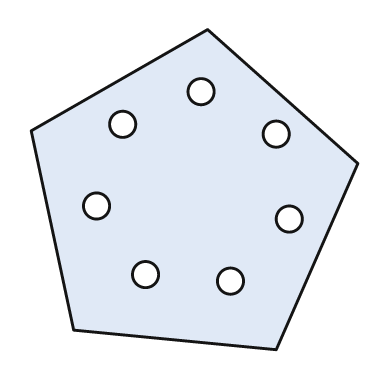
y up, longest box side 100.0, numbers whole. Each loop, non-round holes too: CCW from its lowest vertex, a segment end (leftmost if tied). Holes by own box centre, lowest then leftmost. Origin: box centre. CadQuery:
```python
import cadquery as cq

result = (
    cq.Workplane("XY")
    .moveTo(25.0, -49.0)
    .lineTo(50.0, 8.0)
    .lineTo(4.0, 49.0)
    .lineTo(-50.0, 18.0)
    .lineTo(-37.0, -43.0)
    .close()
    .moveTo(11.0, -28.0)
    .circle(4.0)
    .moveTo(-15.0, -26.0)
    .circle(4.0)
    .moveTo(29.0, -9.0)
    .circle(4.0)
    .moveTo(-30.0, -5.0)
    .circle(4.0)
    .moveTo(25.0, 17.0)
    .circle(4.0)
    .moveTo(-22.0, 20.0)
    .circle(4.0)
    .moveTo(2.0, 30.0)
    .circle(4.0)
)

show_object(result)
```